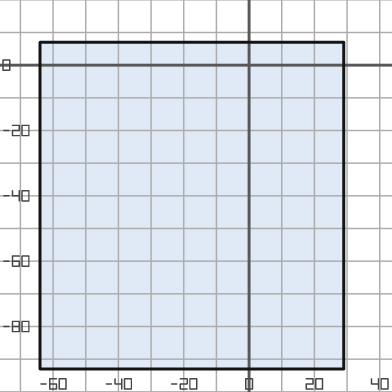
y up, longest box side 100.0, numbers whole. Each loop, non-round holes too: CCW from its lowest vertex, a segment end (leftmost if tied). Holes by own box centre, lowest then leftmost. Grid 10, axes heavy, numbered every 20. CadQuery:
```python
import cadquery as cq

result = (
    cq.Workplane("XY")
    .moveTo(-64.0, -93.0)
    .lineTo(29.0, -93.0)
    .lineTo(29.0, 7.0)
    .lineTo(-64.0, 7.0)
    .close()
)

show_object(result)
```